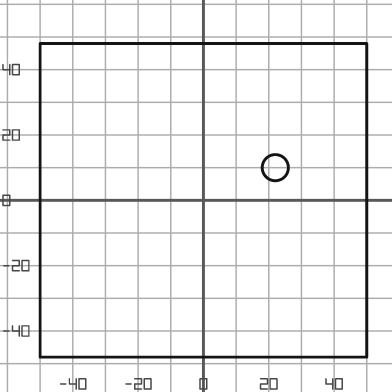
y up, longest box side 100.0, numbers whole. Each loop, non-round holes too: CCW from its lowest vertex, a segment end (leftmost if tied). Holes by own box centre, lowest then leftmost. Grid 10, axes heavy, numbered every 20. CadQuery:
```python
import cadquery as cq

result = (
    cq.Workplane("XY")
    .moveTo(-50.0, -48.0)
    .lineTo(50.0, -48.0)
    .lineTo(50.0, 48.0)
    .lineTo(-50.0, 48.0)
    .close()
    .moveTo(22.0, 10.0)
    .circle(4.0)
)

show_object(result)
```